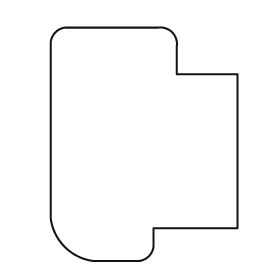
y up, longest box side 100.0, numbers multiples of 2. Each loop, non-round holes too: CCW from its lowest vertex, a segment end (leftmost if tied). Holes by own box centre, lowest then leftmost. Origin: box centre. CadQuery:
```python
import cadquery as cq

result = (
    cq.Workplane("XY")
    .moveTo(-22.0, -50.0)
    .lineTo(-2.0, -50.0)
    .threePointArc((2.0, -48.0), (4.0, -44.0))
    .lineTo(4.0, -36.0)
    .lineTo(40.0, -36.0)
    .lineTo(40.0, 30.0)
    .lineTo(14.0, 30.0)
    .lineTo(14.0, 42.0)
    .threePointArc((12.0, 48.0), (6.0, 50.0))
    .lineTo(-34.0, 50.0)
    .threePointArc((-38.0, 48.0), (-40.0, 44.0))
    .lineTo(-40.0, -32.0)
    .threePointArc((-34.0, -44.0), (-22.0, -50.0))
    .close()
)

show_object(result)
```